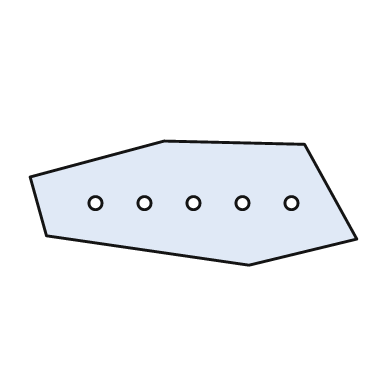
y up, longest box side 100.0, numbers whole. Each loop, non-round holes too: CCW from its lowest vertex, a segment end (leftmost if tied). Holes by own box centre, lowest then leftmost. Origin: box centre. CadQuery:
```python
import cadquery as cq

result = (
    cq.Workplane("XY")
    .moveTo(17.0, -19.0)
    .lineTo(50.0, -11.0)
    .lineTo(34.0, 18.0)
    .lineTo(-9.0, 19.0)
    .lineTo(-50.0, 8.0)
    .lineTo(-45.0, -10.0)
    .close()
    .moveTo(-30.0, 0.0)
    .circle(2.0)
    .moveTo(-15.0, 0.0)
    .circle(2.0)
    .moveTo(0.0, 0.0)
    .circle(2.0)
    .moveTo(15.0, 0.0)
    .circle(2.0)
    .moveTo(30.0, 0.0)
    .circle(2.0)
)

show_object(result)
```